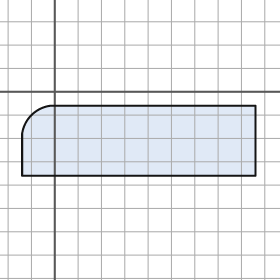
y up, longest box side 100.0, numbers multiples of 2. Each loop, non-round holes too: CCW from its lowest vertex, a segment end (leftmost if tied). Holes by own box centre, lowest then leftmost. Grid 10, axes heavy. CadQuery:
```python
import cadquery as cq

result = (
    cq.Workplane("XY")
    .moveTo(-14.0, -36.0)
    .lineTo(86.0, -36.0)
    .lineTo(86.0, -6.0)
    .lineTo(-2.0, -6.0)
    .threePointArc((-10.0, -10.0), (-14.0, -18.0))
    .close()
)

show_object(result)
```